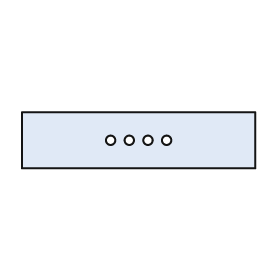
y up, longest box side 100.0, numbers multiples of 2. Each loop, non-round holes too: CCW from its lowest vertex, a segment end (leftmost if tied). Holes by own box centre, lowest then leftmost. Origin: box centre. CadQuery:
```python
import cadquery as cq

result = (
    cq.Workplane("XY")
    .moveTo(-50.0, -12.0)
    .lineTo(50.0, -12.0)
    .lineTo(50.0, 12.0)
    .lineTo(-50.0, 12.0)
    .close()
    .moveTo(-12.0, 0.0)
    .circle(2.0)
    .moveTo(-4.0, 0.0)
    .circle(2.0)
    .moveTo(4.0, 0.0)
    .circle(2.0)
    .moveTo(12.0, 0.0)
    .circle(2.0)
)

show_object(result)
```